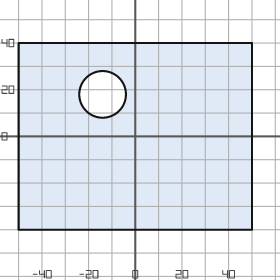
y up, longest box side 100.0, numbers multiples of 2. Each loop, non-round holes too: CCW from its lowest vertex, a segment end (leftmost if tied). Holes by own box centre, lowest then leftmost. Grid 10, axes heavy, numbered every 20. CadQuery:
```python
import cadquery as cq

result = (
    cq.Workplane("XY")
    .moveTo(-50.0, -40.0)
    .lineTo(50.0, -40.0)
    .lineTo(50.0, 40.0)
    .lineTo(-50.0, 40.0)
    .close()
    .moveTo(-14.0, 18.0)
    .circle(10.0)
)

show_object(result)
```